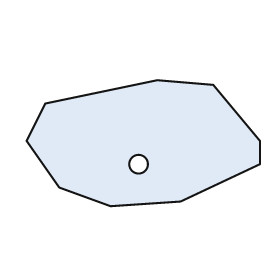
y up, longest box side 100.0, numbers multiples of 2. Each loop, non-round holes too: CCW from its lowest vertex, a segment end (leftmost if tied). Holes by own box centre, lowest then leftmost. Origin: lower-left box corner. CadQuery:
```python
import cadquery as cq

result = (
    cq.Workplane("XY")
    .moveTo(36.0, 0.0)
    .lineTo(66.0, 2.0)
    .lineTo(100.0, 18.0)
    .lineTo(100.0, 28.0)
    .lineTo(80.0, 52.0)
    .lineTo(56.0, 54.0)
    .lineTo(8.0, 44.0)
    .lineTo(0.0, 28.0)
    .lineTo(14.0, 8.0)
    .close()
    .moveTo(48.0, 18.0)
    .circle(4.0)
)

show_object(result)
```